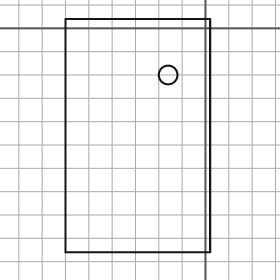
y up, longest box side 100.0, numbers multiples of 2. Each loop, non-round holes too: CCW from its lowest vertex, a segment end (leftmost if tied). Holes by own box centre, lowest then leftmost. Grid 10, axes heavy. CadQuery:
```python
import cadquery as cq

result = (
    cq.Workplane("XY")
    .moveTo(-60.0, -96.0)
    .lineTo(2.0, -96.0)
    .lineTo(2.0, 4.0)
    .lineTo(-60.0, 4.0)
    .close()
    .moveTo(-16.0, -20.0)
    .circle(4.0)
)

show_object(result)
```